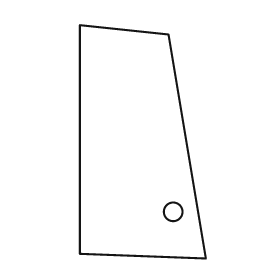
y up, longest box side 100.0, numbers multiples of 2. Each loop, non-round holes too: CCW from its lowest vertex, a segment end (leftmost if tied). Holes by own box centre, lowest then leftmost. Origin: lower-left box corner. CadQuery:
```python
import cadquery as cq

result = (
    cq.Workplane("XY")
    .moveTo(54.0, 0.0)
    .lineTo(38.0, 96.0)
    .lineTo(0.0, 100.0)
    .lineTo(0.0, 2.0)
    .close()
    .moveTo(40.0, 20.0)
    .circle(4.0)
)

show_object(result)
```